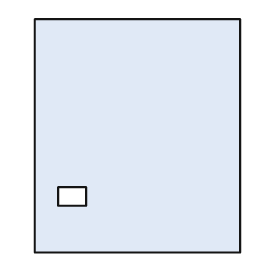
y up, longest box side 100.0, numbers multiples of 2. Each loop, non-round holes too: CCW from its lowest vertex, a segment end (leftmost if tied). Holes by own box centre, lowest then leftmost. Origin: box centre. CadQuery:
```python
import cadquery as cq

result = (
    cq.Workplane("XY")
    .moveTo(-44.0, -50.0)
    .lineTo(44.0, -50.0)
    .lineTo(44.0, 50.0)
    .lineTo(-44.0, 50.0)
    .close()
    .moveTo(-34.0, -30.0)
    .lineTo(-22.0, -30.0)
    .lineTo(-22.0, -22.0)
    .lineTo(-34.0, -22.0)
    .close()
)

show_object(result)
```